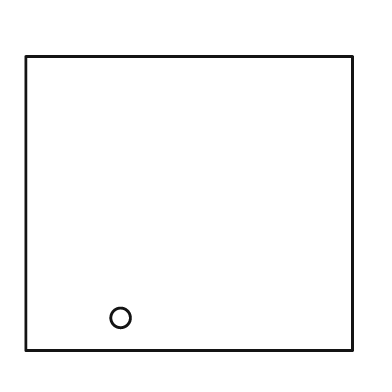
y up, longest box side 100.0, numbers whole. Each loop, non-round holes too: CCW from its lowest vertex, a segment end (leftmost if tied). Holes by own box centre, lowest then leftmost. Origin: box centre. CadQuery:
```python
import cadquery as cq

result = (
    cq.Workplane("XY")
    .moveTo(-50.0, -45.0)
    .lineTo(50.0, -45.0)
    .lineTo(50.0, 45.0)
    .lineTo(-50.0, 45.0)
    .close()
    .moveTo(-21.0, -35.0)
    .circle(3.0)
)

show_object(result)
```